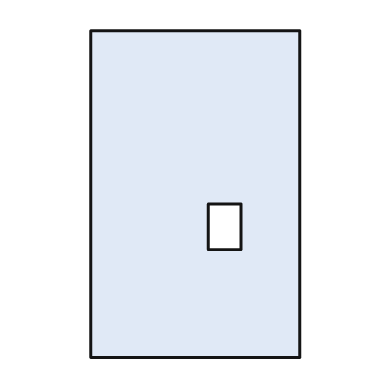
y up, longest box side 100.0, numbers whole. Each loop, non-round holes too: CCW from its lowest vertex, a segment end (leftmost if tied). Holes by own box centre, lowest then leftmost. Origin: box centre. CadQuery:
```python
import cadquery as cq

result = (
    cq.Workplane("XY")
    .moveTo(-32.0, -50.0)
    .lineTo(32.0, -50.0)
    .lineTo(32.0, 50.0)
    .lineTo(-32.0, 50.0)
    .close()
    .moveTo(4.0, -17.0)
    .lineTo(14.0, -17.0)
    .lineTo(14.0, -3.0)
    .lineTo(4.0, -3.0)
    .close()
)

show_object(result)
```